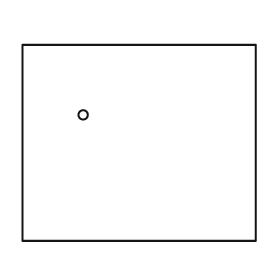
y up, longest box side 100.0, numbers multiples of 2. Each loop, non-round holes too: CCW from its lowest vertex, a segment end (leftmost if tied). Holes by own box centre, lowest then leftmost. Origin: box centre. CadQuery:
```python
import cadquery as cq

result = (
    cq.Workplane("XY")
    .moveTo(-50.0, -42.0)
    .lineTo(50.0, -42.0)
    .lineTo(50.0, 42.0)
    .lineTo(-50.0, 42.0)
    .close()
    .moveTo(-24.0, 12.0)
    .circle(2.0)
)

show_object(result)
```